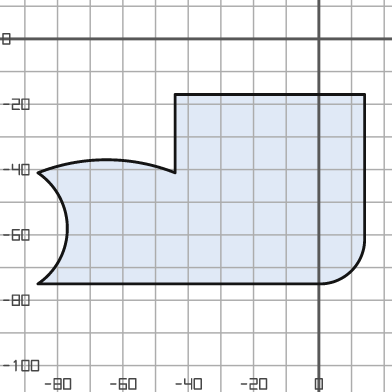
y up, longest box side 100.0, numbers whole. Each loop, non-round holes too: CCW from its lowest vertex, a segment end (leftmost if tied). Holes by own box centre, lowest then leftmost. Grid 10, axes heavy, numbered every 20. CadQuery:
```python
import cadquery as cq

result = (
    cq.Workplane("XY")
    .moveTo(-86.0, -75.0)
    .lineTo(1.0, -75.0)
    .threePointArc((10.0, -71.0), (14.0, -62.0))
    .lineTo(14.0, -17.0)
    .lineTo(-44.0, -17.0)
    .lineTo(-44.0, -41.0)
    .threePointArc((-65.0, -37.0), (-86.0, -41.0))
    .threePointArc((-77.0, -58.0), (-86.0, -75.0))
    .close()
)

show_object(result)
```